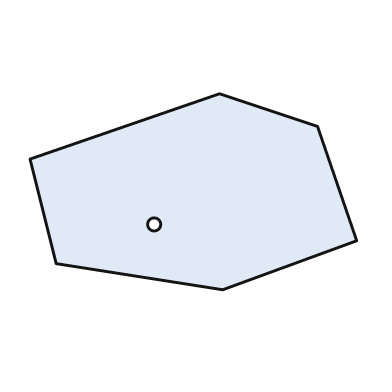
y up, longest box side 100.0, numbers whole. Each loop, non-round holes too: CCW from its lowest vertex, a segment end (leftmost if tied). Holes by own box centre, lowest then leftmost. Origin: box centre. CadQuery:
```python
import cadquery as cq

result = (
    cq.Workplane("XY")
    .moveTo(9.0, -30.0)
    .lineTo(50.0, -15.0)
    .lineTo(38.0, 20.0)
    .lineTo(8.0, 30.0)
    .lineTo(-50.0, 10.0)
    .lineTo(-42.0, -22.0)
    .close()
    .moveTo(-12.0, -10.0)
    .circle(2.0)
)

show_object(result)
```